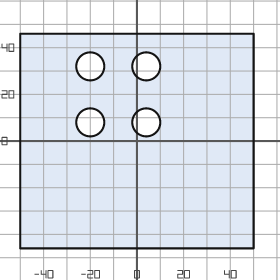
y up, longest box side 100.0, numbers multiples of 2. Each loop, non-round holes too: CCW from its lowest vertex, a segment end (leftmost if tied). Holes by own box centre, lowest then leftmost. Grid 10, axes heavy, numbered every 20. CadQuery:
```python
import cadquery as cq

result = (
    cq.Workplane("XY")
    .moveTo(-50.0, -46.0)
    .lineTo(50.0, -46.0)
    .lineTo(50.0, 46.0)
    .lineTo(-50.0, 46.0)
    .close()
    .moveTo(-20.0, 8.0)
    .circle(6.0)
    .moveTo(4.0, 8.0)
    .circle(6.0)
    .moveTo(-20.0, 32.0)
    .circle(6.0)
    .moveTo(4.0, 32.0)
    .circle(6.0)
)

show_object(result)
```